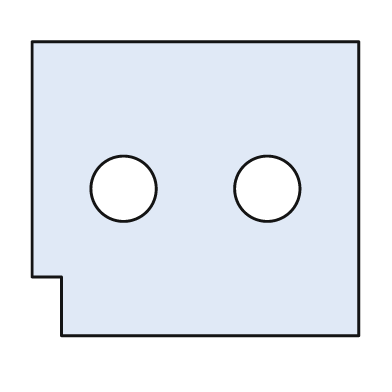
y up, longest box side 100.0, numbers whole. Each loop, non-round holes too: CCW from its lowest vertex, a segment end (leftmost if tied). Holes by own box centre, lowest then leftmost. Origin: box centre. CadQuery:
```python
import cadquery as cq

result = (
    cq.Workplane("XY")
    .moveTo(-41.0, -45.0)
    .lineTo(50.0, -45.0)
    .lineTo(50.0, 45.0)
    .lineTo(-50.0, 45.0)
    .lineTo(-50.0, -27.0)
    .lineTo(-41.0, -27.0)
    .close()
    .moveTo(-22.0, 0.0)
    .circle(10.0)
    .moveTo(22.0, 0.0)
    .circle(10.0)
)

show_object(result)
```